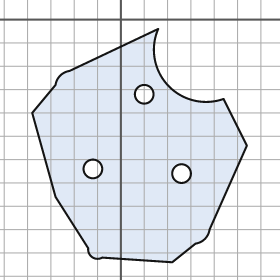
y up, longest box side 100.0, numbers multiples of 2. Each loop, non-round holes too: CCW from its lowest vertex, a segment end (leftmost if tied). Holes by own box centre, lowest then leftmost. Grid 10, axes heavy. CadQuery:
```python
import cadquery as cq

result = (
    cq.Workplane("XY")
    .moveTo(22.0, -104.0)
    .lineTo(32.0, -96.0)
    .threePointArc((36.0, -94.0), (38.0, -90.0))
    .lineTo(54.0, -54.0)
    .lineTo(44.0, -34.0)
    .threePointArc((20.0, -28.0), (16.0, -4.0))
    .lineTo(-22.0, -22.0)
    .threePointArc((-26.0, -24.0), (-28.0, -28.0))
    .lineTo(-38.0, -40.0)
    .lineTo(-28.0, -76.0)
    .lineTo(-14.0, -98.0)
    .threePointArc((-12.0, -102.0), (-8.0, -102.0))
    .close()
    .moveTo(26.0, -66.0)
    .circle(4.0)
    .moveTo(-12.0, -64.0)
    .circle(4.0)
    .moveTo(10.0, -32.0)
    .circle(4.0)
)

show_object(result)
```